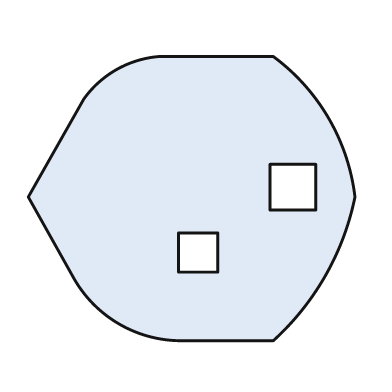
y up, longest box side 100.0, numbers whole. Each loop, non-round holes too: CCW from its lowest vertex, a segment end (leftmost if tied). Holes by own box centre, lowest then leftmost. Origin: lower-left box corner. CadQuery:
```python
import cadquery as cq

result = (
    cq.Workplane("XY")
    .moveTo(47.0, 0.0)
    .lineTo(75.0, 0.0)
    .threePointArc((91.0, 20.0), (100.0, 44.0))
    .threePointArc((92.0, 68.0), (75.0, 87.0))
    .lineTo(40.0, 87.0)
    .threePointArc((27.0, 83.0), (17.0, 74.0))
    .lineTo(0.0, 44.0)
    .lineTo(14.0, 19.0)
    .threePointArc((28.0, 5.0), (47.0, 0.0))
    .close()
    .moveTo(46.0, 21.0)
    .lineTo(58.0, 21.0)
    .lineTo(58.0, 33.0)
    .lineTo(46.0, 33.0)
    .close()
    .moveTo(74.0, 40.0)
    .lineTo(88.0, 40.0)
    .lineTo(88.0, 54.0)
    .lineTo(74.0, 54.0)
    .close()
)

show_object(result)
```